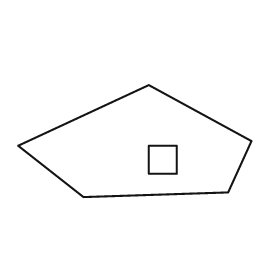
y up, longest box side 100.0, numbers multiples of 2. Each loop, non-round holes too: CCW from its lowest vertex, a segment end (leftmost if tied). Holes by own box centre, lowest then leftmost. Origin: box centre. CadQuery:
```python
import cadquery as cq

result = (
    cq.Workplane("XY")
    .moveTo(-22.0, -24.0)
    .lineTo(40.0, -22.0)
    .lineTo(50.0, 0.0)
    .lineTo(6.0, 24.0)
    .lineTo(-50.0, -2.0)
    .close()
    .moveTo(6.0, -14.0)
    .lineTo(18.0, -14.0)
    .lineTo(18.0, -2.0)
    .lineTo(6.0, -2.0)
    .close()
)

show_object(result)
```